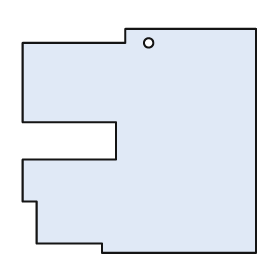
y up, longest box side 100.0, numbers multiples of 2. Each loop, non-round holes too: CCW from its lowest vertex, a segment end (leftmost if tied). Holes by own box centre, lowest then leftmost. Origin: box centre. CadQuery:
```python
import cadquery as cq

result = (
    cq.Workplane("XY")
    .moveTo(-16.0, -48.0)
    .lineTo(50.0, -48.0)
    .lineTo(50.0, 48.0)
    .lineTo(-6.0, 48.0)
    .lineTo(-6.0, 42.0)
    .lineTo(-50.0, 42.0)
    .lineTo(-50.0, 8.0)
    .lineTo(-10.0, 8.0)
    .lineTo(-10.0, -8.0)
    .lineTo(-50.0, -8.0)
    .lineTo(-50.0, -26.0)
    .lineTo(-44.0, -26.0)
    .lineTo(-44.0, -44.0)
    .lineTo(-16.0, -44.0)
    .close()
    .moveTo(4.0, 42.0)
    .circle(2.0)
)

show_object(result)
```